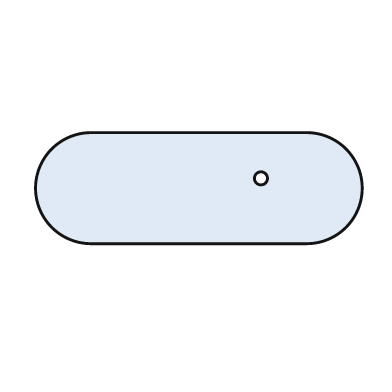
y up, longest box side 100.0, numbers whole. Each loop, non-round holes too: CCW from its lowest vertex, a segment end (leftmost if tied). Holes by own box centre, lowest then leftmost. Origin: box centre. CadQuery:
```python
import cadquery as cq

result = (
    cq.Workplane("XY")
    .moveTo(-33.0, -17.0)
    .lineTo(33.0, -17.0)
    .threePointArc((50.0, 0.0), (33.0, 17.0))
    .lineTo(-33.0, 17.0)
    .threePointArc((-50.0, 0.0), (-33.0, -17.0))
    .close()
    .moveTo(19.0, 3.0)
    .circle(2.0)
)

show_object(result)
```